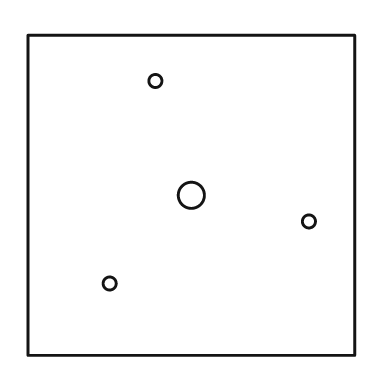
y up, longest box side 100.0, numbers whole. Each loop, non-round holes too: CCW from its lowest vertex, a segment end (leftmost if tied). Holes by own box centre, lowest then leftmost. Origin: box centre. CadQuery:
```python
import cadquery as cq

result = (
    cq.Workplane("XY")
    .moveTo(-50.0, -49.0)
    .lineTo(50.0, -49.0)
    .lineTo(50.0, 49.0)
    .lineTo(-50.0, 49.0)
    .close()
    .moveTo(-25.0, -27.0)
    .circle(2.0)
    .moveTo(36.0, -8.0)
    .circle(2.0)
    .moveTo(0.0, 0.0)
    .circle(4.0)
    .moveTo(-11.0, 35.0)
    .circle(2.0)
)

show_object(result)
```